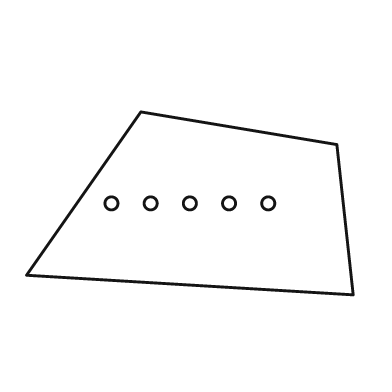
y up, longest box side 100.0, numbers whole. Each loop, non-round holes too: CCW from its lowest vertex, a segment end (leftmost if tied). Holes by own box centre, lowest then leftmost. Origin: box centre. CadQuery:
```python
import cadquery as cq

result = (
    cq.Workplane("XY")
    .moveTo(50.0, -28.0)
    .lineTo(45.0, 18.0)
    .lineTo(-15.0, 28.0)
    .lineTo(-50.0, -22.0)
    .close()
    .moveTo(-24.0, 0.0)
    .circle(2.0)
    .moveTo(-12.0, 0.0)
    .circle(2.0)
    .moveTo(0.0, 0.0)
    .circle(2.0)
    .moveTo(12.0, 0.0)
    .circle(2.0)
    .moveTo(24.0, 0.0)
    .circle(2.0)
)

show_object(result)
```